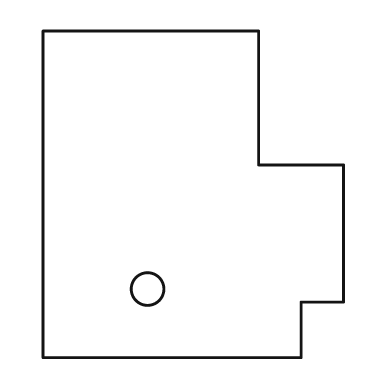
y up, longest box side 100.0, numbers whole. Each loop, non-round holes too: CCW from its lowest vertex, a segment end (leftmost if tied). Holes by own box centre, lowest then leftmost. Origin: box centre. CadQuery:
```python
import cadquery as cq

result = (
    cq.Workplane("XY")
    .moveTo(-46.0, -50.0)
    .lineTo(33.0, -50.0)
    .lineTo(33.0, -33.0)
    .lineTo(46.0, -33.0)
    .lineTo(46.0, 9.0)
    .lineTo(20.0, 9.0)
    .lineTo(20.0, 50.0)
    .lineTo(-46.0, 50.0)
    .close()
    .moveTo(-14.0, -29.0)
    .circle(5.0)
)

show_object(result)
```